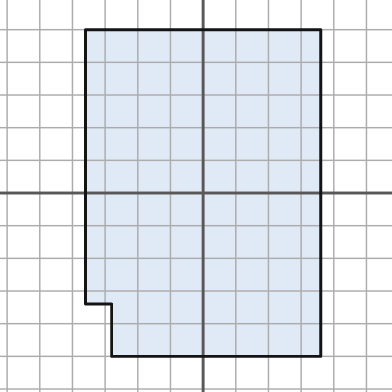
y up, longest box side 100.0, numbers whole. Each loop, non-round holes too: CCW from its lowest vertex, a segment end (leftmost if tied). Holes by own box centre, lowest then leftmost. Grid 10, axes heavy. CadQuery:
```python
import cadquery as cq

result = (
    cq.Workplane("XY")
    .moveTo(-28.0, -50.0)
    .lineTo(36.0, -50.0)
    .lineTo(36.0, 50.0)
    .lineTo(-36.0, 50.0)
    .lineTo(-36.0, -34.0)
    .lineTo(-28.0, -34.0)
    .close()
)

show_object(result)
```